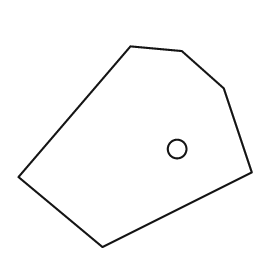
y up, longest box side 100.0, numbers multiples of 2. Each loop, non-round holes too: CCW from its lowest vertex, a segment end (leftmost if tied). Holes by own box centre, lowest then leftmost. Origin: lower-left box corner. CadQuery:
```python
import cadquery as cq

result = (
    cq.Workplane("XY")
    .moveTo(36.0, 0.0)
    .lineTo(100.0, 32.0)
    .lineTo(88.0, 68.0)
    .lineTo(70.0, 84.0)
    .lineTo(48.0, 86.0)
    .lineTo(0.0, 30.0)
    .close()
    .moveTo(68.0, 42.0)
    .circle(4.0)
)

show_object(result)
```